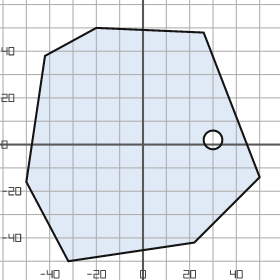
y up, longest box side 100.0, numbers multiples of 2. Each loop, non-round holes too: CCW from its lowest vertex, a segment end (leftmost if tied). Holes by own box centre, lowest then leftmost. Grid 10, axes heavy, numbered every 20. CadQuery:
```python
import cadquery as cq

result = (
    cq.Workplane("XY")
    .moveTo(-32.0, -50.0)
    .lineTo(22.0, -42.0)
    .lineTo(50.0, -14.0)
    .lineTo(26.0, 48.0)
    .lineTo(-20.0, 50.0)
    .lineTo(-42.0, 38.0)
    .lineTo(-50.0, -16.0)
    .close()
    .moveTo(30.0, 2.0)
    .circle(4.0)
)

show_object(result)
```